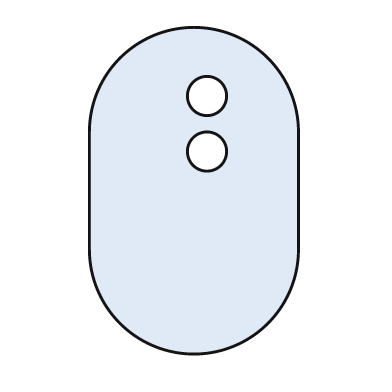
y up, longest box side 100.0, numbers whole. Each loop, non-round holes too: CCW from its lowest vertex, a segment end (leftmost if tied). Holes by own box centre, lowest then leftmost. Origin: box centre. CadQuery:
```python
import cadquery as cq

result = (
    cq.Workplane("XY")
    .moveTo(-32.0, -18.0)
    .threePointArc((0.0, -50.0), (32.0, -18.0))
    .lineTo(32.0, 18.0)
    .threePointArc((0.0, 50.0), (-32.0, 18.0))
    .close()
    .moveTo(4.0, 12.0)
    .circle(6.0)
    .moveTo(4.0, 29.0)
    .circle(6.0)
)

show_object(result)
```